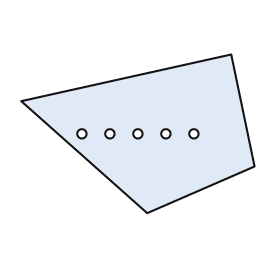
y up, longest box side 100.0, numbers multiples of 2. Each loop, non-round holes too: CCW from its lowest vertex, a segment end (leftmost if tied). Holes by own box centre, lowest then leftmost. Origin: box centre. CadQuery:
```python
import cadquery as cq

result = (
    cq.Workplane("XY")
    .moveTo(4.0, -34.0)
    .lineTo(50.0, -14.0)
    .lineTo(40.0, 34.0)
    .lineTo(-50.0, 14.0)
    .close()
    .moveTo(-24.0, 0.0)
    .circle(2.0)
    .moveTo(-12.0, 0.0)
    .circle(2.0)
    .moveTo(0.0, 0.0)
    .circle(2.0)
    .moveTo(12.0, 0.0)
    .circle(2.0)
    .moveTo(24.0, 0.0)
    .circle(2.0)
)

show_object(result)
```